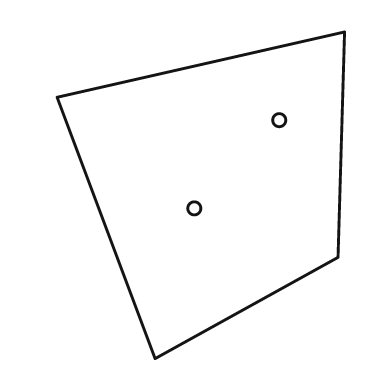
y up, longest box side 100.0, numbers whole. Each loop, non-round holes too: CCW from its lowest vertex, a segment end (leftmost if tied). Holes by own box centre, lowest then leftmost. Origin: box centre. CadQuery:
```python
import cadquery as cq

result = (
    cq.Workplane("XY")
    .moveTo(-14.0, -50.0)
    .lineTo(42.0, -19.0)
    .lineTo(44.0, 50.0)
    .lineTo(-44.0, 30.0)
    .close()
    .moveTo(-2.0, -4.0)
    .circle(2.0)
    .moveTo(24.0, 23.0)
    .circle(2.0)
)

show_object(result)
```